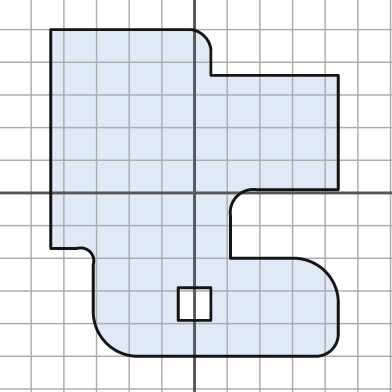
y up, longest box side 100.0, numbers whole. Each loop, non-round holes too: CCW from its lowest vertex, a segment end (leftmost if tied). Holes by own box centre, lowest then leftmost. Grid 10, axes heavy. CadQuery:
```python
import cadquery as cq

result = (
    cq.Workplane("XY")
    .moveTo(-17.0, -50.0)
    .lineTo(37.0, -50.0)
    .threePointArc((42.0, -48.0), (44.0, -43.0))
    .lineTo(44.0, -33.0)
    .threePointArc((40.0, -24.0), (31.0, -20.0))
    .lineTo(11.0, -20.0)
    .lineTo(11.0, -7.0)
    .threePointArc((13.0, -1.0), (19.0, 1.0))
    .lineTo(44.0, 1.0)
    .lineTo(44.0, 36.0)
    .lineTo(5.0, 36.0)
    .lineTo(5.0, 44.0)
    .threePointArc((3.0, 48.0), (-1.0, 50.0))
    .lineTo(-44.0, 50.0)
    .lineTo(-44.0, -17.0)
    .lineTo(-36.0, -17.0)
    .threePointArc((-32.0, -18.0), (-31.0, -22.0))
    .lineTo(-31.0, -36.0)
    .threePointArc((-27.0, -46.0), (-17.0, -50.0))
    .close()
    .moveTo(-5.0, -39.0)
    .lineTo(5.0, -39.0)
    .lineTo(5.0, -29.0)
    .lineTo(-5.0, -29.0)
    .close()
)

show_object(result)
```